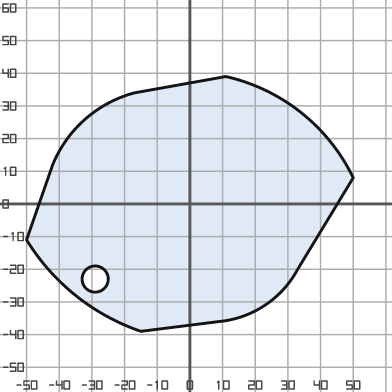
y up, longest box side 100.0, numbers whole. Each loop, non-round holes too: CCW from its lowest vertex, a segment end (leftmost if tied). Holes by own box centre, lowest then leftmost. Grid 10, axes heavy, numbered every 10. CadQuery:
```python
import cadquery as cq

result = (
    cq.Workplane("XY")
    .moveTo(-15.0, -39.0)
    .lineTo(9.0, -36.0)
    .threePointArc((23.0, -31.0), (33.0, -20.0))
    .lineTo(50.0, 8.0)
    .threePointArc((34.0, 28.0), (11.0, 39.0))
    .lineTo(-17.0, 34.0)
    .threePointArc((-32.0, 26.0), (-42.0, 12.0))
    .lineTo(-50.0, -11.0)
    .threePointArc((-35.0, -28.0), (-15.0, -39.0))
    .close()
    .moveTo(-29.0, -23.0)
    .circle(4.0)
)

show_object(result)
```